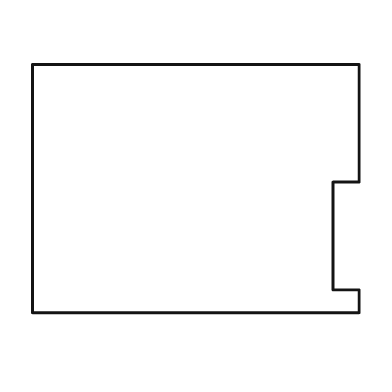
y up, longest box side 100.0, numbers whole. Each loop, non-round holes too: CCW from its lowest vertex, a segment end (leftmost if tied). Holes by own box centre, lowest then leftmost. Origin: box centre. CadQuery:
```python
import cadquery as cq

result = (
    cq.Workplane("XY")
    .moveTo(-50.0, -38.0)
    .lineTo(50.0, -38.0)
    .lineTo(50.0, -31.0)
    .lineTo(42.0, -31.0)
    .lineTo(42.0, 2.0)
    .lineTo(50.0, 2.0)
    .lineTo(50.0, 38.0)
    .lineTo(-50.0, 38.0)
    .close()
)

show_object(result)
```